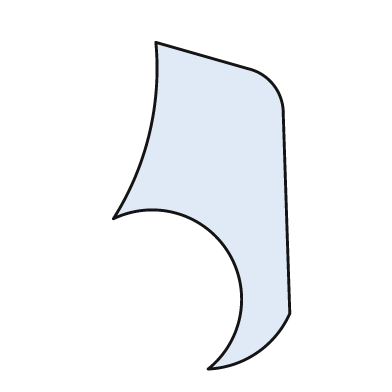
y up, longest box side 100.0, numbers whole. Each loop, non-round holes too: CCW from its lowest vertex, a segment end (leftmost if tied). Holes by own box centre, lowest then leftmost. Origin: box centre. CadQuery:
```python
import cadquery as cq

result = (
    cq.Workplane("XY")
    .moveTo(2.0, -50.0)
    .threePointArc((17.0, -45.0), (27.0, -33.0))
    .lineTo(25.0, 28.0)
    .threePointArc((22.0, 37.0), (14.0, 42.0))
    .lineTo(-14.0, 50.0)
    .threePointArc((-16.0, 22.0), (-27.0, -4.0))
    .threePointArc((8.0, -14.0), (2.0, -50.0))
    .close()
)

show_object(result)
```